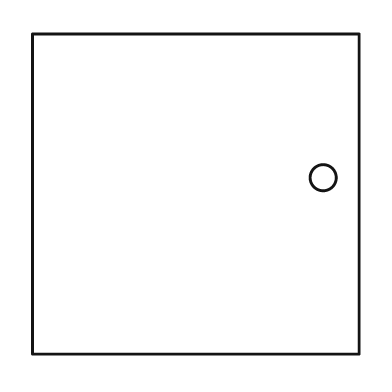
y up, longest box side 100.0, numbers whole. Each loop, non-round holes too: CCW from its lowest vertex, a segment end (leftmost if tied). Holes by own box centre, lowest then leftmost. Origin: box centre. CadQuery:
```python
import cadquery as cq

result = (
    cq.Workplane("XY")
    .moveTo(-50.0, -49.0)
    .lineTo(50.0, -49.0)
    .lineTo(50.0, 49.0)
    .lineTo(-50.0, 49.0)
    .close()
    .moveTo(39.0, 5.0)
    .circle(4.0)
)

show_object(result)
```